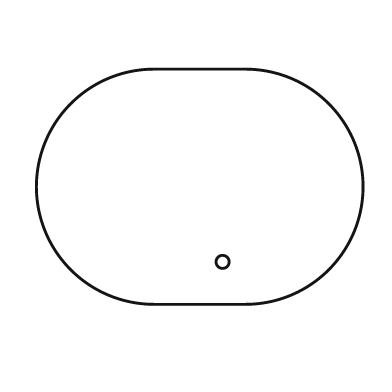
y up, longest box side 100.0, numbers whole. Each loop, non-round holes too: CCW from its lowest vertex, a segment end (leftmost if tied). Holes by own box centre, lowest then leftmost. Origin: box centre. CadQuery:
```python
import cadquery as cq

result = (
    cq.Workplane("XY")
    .moveTo(-14.0, -36.0)
    .lineTo(14.0, -36.0)
    .threePointArc((50.0, 0.0), (14.0, 36.0))
    .lineTo(-14.0, 36.0)
    .threePointArc((-50.0, 0.0), (-14.0, -36.0))
    .close()
    .moveTo(7.0, -23.0)
    .circle(2.0)
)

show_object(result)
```